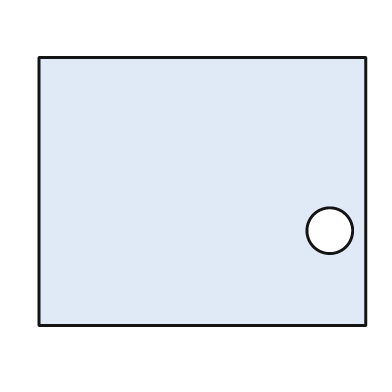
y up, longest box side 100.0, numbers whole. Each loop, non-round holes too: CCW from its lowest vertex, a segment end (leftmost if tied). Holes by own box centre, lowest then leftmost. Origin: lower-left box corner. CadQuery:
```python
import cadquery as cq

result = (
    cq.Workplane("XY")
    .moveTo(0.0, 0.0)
    .lineTo(100.0, 0.0)
    .lineTo(100.0, 82.0)
    .lineTo(0.0, 82.0)
    .close()
    .moveTo(89.0, 29.0)
    .circle(7.0)
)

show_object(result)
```